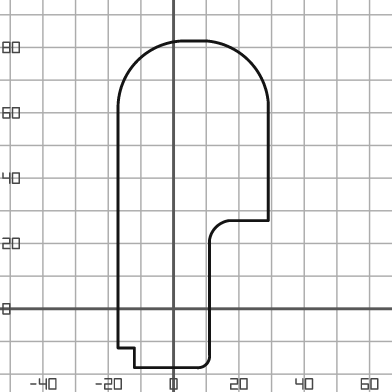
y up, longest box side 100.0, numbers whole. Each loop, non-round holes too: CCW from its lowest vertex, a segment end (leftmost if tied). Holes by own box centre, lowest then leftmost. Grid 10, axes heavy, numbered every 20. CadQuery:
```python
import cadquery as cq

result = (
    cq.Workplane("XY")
    .moveTo(-12.0, -18.0)
    .lineTo(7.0, -18.0)
    .threePointArc((10.0, -17.0), (11.0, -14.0))
    .lineTo(11.0, 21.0)
    .threePointArc((13.0, 25.0), (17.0, 27.0))
    .lineTo(29.0, 27.0)
    .lineTo(29.0, 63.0)
    .threePointArc((23.0, 76.0), (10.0, 82.0))
    .lineTo(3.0, 82.0)
    .threePointArc((-11.0, 76.0), (-17.0, 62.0))
    .lineTo(-17.0, -12.0)
    .lineTo(-12.0, -12.0)
    .close()
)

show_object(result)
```